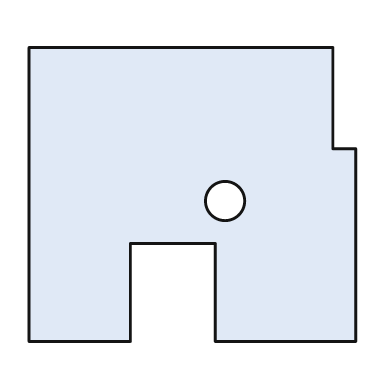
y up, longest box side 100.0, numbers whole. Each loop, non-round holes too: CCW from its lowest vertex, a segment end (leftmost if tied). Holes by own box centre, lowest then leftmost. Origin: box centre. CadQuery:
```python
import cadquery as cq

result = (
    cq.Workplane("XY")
    .moveTo(-50.0, -45.0)
    .lineTo(-19.0, -45.0)
    .lineTo(-19.0, -15.0)
    .lineTo(7.0, -15.0)
    .lineTo(7.0, -45.0)
    .lineTo(50.0, -45.0)
    .lineTo(50.0, 14.0)
    .lineTo(43.0, 14.0)
    .lineTo(43.0, 45.0)
    .lineTo(-50.0, 45.0)
    .close()
    .moveTo(10.0, -2.0)
    .circle(6.0)
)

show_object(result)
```